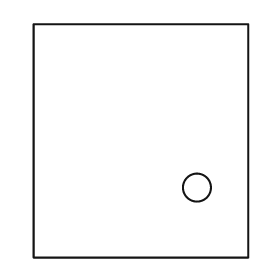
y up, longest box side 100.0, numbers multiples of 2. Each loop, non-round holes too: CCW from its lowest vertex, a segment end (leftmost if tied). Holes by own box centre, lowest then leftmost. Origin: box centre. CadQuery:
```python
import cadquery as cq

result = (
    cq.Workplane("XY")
    .moveTo(-46.0, -50.0)
    .lineTo(46.0, -50.0)
    .lineTo(46.0, 50.0)
    .lineTo(-46.0, 50.0)
    .close()
    .moveTo(24.0, -20.0)
    .circle(6.0)
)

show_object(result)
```